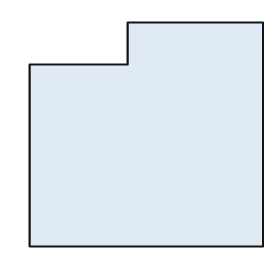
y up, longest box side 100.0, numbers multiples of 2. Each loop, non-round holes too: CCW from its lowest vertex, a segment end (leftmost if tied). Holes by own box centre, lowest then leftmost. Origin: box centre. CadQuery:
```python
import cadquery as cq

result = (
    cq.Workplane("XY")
    .moveTo(-50.0, -48.0)
    .lineTo(50.0, -48.0)
    .lineTo(50.0, 48.0)
    .lineTo(-8.0, 48.0)
    .lineTo(-8.0, 30.0)
    .lineTo(-50.0, 30.0)
    .close()
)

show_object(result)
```